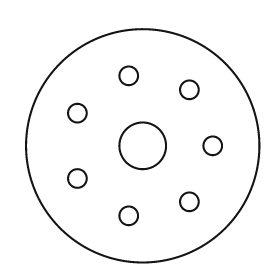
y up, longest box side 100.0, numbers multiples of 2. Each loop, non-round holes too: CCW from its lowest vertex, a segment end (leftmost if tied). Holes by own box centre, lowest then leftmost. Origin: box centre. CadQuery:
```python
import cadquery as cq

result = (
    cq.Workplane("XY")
    .moveTo(0.0, 0.0)
    .circle(50.0)
    .moveTo(-6.0, -30.0)
    .circle(4.0)
    .moveTo(20.0, -24.0)
    .circle(4.0)
    .moveTo(-28.0, -14.0)
    .circle(4.0)
    .moveTo(0.0, 0.0)
    .circle(10.0)
    .moveTo(30.0, 0.0)
    .circle(4.0)
    .moveTo(-28.0, 14.0)
    .circle(4.0)
    .moveTo(20.0, 24.0)
    .circle(4.0)
    .moveTo(-6.0, 30.0)
    .circle(4.0)
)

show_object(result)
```